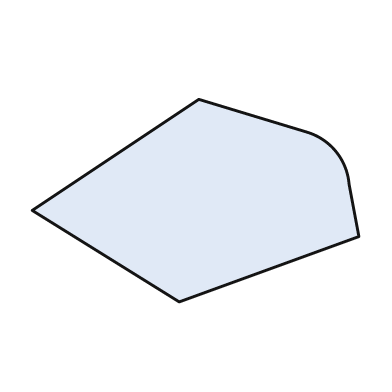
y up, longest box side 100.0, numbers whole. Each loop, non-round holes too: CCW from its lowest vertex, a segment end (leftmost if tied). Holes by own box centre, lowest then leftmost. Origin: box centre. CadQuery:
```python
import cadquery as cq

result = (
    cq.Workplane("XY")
    .moveTo(-5.0, -31.0)
    .lineTo(50.0, -11.0)
    .lineTo(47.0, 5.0)
    .threePointArc((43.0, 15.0), (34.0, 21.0))
    .lineTo(1.0, 31.0)
    .lineTo(-50.0, -3.0)
    .close()
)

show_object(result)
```